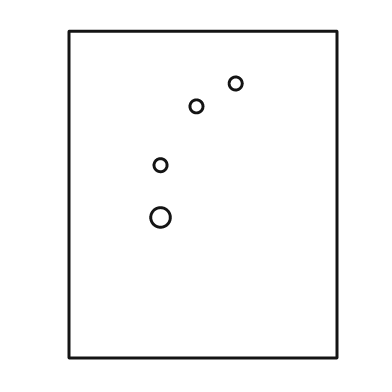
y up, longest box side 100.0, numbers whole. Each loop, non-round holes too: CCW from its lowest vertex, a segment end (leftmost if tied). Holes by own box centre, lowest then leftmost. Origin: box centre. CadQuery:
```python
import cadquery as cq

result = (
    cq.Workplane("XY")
    .moveTo(-41.0, -50.0)
    .lineTo(41.0, -50.0)
    .lineTo(41.0, 50.0)
    .lineTo(-41.0, 50.0)
    .close()
    .moveTo(-13.0, -7.0)
    .circle(3.0)
    .moveTo(-13.0, 9.0)
    .circle(2.0)
    .moveTo(-2.0, 27.0)
    .circle(2.0)
    .moveTo(10.0, 34.0)
    .circle(2.0)
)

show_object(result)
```